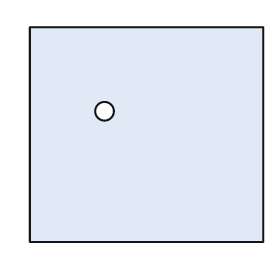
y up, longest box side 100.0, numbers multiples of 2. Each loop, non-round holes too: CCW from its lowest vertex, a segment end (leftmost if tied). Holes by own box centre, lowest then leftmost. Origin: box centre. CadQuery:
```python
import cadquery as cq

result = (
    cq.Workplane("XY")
    .moveTo(-50.0, -46.0)
    .lineTo(50.0, -46.0)
    .lineTo(50.0, 46.0)
    .lineTo(-50.0, 46.0)
    .close()
    .moveTo(-18.0, 10.0)
    .circle(4.0)
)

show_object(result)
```